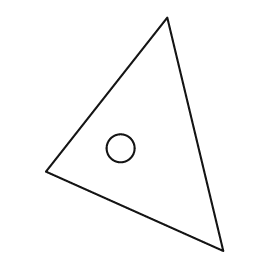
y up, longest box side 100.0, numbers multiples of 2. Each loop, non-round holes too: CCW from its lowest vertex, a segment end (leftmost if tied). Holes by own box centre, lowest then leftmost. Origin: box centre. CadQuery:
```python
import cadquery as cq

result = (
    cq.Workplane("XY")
    .moveTo(38.0, -50.0)
    .lineTo(14.0, 50.0)
    .lineTo(-38.0, -16.0)
    .close()
    .moveTo(-6.0, -6.0)
    .circle(6.0)
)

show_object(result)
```